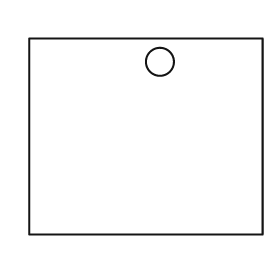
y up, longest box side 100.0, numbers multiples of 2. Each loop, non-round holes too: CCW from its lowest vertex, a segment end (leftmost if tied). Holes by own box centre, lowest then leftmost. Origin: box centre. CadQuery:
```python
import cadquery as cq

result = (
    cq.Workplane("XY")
    .moveTo(-50.0, -42.0)
    .lineTo(50.0, -42.0)
    .lineTo(50.0, 42.0)
    .lineTo(-50.0, 42.0)
    .close()
    .moveTo(6.0, 32.0)
    .circle(6.0)
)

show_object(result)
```